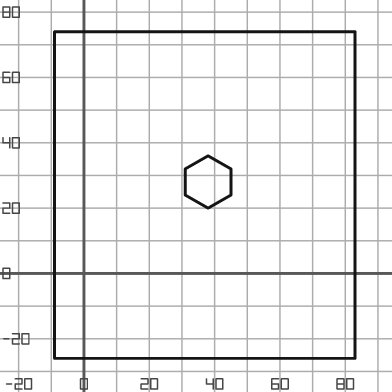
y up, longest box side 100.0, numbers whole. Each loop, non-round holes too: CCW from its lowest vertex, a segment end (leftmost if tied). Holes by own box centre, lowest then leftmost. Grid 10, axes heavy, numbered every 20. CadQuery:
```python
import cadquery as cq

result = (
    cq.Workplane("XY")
    .moveTo(-9.0, -26.0)
    .lineTo(83.0, -26.0)
    .lineTo(83.0, 74.0)
    .lineTo(-9.0, 74.0)
    .close()
    .moveTo(38.0, 20.0)
    .lineTo(45.0, 24.0)
    .lineTo(45.0, 32.0)
    .lineTo(38.0, 36.0)
    .lineTo(31.0, 32.0)
    .lineTo(31.0, 24.0)
    .close()
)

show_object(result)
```